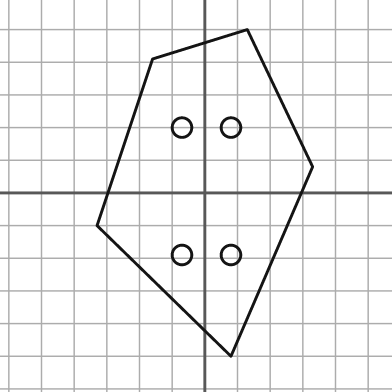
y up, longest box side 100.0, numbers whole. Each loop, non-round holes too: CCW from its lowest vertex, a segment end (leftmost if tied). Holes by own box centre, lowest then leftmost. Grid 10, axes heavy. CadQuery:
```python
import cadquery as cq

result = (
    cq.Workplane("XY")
    .moveTo(8.0, -50.0)
    .lineTo(33.0, 8.0)
    .lineTo(13.0, 50.0)
    .lineTo(-16.0, 41.0)
    .lineTo(-33.0, -10.0)
    .close()
    .moveTo(-7.0, -19.0)
    .circle(3.0)
    .moveTo(8.0, -19.0)
    .circle(3.0)
    .moveTo(-7.0, 20.0)
    .circle(3.0)
    .moveTo(8.0, 20.0)
    .circle(3.0)
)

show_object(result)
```